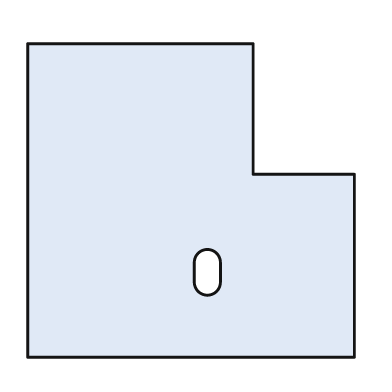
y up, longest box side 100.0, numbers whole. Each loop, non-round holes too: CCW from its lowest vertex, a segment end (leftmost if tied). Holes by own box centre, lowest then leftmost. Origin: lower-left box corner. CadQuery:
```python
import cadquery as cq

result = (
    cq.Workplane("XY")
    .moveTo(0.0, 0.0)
    .lineTo(100.0, 0.0)
    .lineTo(100.0, 56.0)
    .lineTo(69.0, 56.0)
    .lineTo(69.0, 96.0)
    .lineTo(0.0, 96.0)
    .close()
    .moveTo(51.0, 23.0)
    .threePointArc((55.0, 19.0), (59.0, 23.0))
    .lineTo(59.0, 29.0)
    .threePointArc((55.0, 33.0), (51.0, 29.0))
    .close()
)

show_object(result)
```